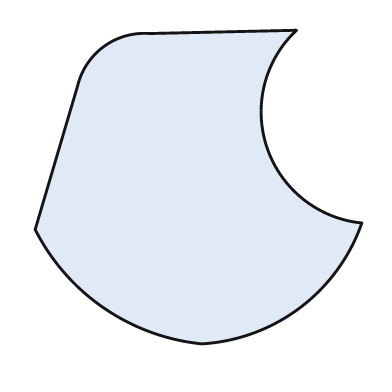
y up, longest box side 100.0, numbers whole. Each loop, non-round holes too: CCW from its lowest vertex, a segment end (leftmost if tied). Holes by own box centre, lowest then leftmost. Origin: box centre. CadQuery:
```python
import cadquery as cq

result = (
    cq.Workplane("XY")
    .moveTo(1.0, -48.0)
    .threePointArc((31.0, -37.0), (50.0, -11.0))
    .threePointArc((21.0, 12.0), (30.0, 48.0))
    .lineTo(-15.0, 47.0)
    .threePointArc((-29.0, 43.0), (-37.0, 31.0))
    .lineTo(-50.0, -13.0)
    .threePointArc((-29.0, -37.0), (1.0, -48.0))
    .close()
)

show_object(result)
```